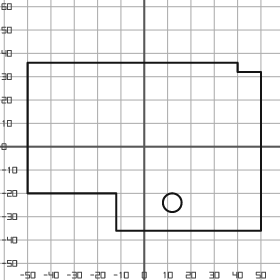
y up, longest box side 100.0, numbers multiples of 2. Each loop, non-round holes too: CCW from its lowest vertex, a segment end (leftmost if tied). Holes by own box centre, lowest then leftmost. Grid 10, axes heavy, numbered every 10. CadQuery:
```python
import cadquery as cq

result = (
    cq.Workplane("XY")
    .moveTo(-12.0, -36.0)
    .lineTo(50.0, -36.0)
    .lineTo(50.0, 32.0)
    .lineTo(40.0, 32.0)
    .lineTo(40.0, 36.0)
    .lineTo(-50.0, 36.0)
    .lineTo(-50.0, -20.0)
    .lineTo(-12.0, -20.0)
    .close()
    .moveTo(12.0, -24.0)
    .circle(4.0)
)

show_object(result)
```